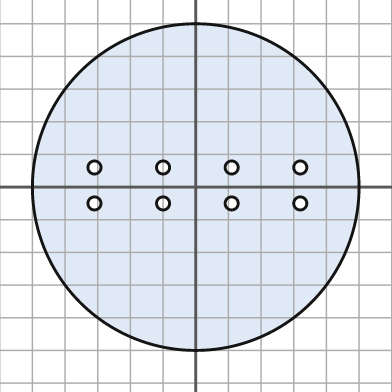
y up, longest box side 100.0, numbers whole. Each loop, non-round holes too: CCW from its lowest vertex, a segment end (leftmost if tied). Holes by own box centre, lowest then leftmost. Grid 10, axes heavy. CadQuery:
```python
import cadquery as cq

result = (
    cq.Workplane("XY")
    .moveTo(0.0, 0.0)
    .circle(50.0)
    .moveTo(-31.0, -5.0)
    .circle(2.0)
    .moveTo(-10.0, -5.0)
    .circle(2.0)
    .moveTo(11.0, -5.0)
    .circle(2.0)
    .moveTo(32.0, -5.0)
    .circle(2.0)
    .moveTo(-31.0, 6.0)
    .circle(2.0)
    .moveTo(-10.0, 6.0)
    .circle(2.0)
    .moveTo(11.0, 6.0)
    .circle(2.0)
    .moveTo(32.0, 6.0)
    .circle(2.0)
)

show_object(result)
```